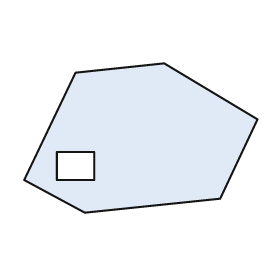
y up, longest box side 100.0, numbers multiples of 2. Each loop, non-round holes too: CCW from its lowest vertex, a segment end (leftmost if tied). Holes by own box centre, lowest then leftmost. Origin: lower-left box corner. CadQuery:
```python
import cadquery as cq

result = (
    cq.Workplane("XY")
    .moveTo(26.0, 0.0)
    .lineTo(84.0, 6.0)
    .lineTo(100.0, 40.0)
    .lineTo(60.0, 64.0)
    .lineTo(22.0, 60.0)
    .lineTo(0.0, 14.0)
    .close()
    .moveTo(14.0, 14.0)
    .lineTo(30.0, 14.0)
    .lineTo(30.0, 26.0)
    .lineTo(14.0, 26.0)
    .close()
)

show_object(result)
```